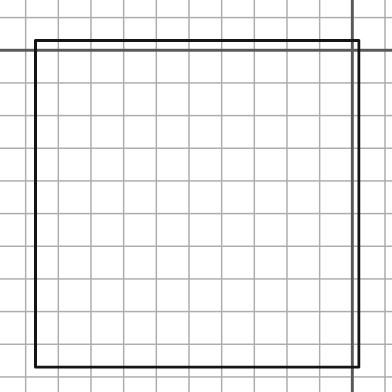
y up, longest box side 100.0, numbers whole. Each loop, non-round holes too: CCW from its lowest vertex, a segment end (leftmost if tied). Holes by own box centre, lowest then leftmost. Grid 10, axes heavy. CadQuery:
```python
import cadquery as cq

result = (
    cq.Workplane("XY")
    .moveTo(-97.0, -97.0)
    .lineTo(2.0, -97.0)
    .lineTo(2.0, 3.0)
    .lineTo(-97.0, 3.0)
    .close()
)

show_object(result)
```